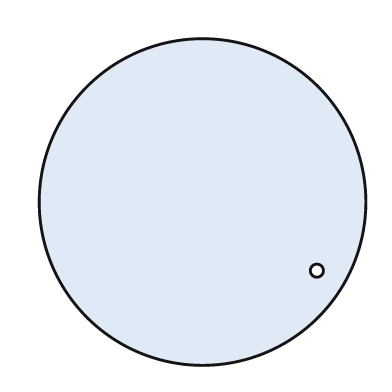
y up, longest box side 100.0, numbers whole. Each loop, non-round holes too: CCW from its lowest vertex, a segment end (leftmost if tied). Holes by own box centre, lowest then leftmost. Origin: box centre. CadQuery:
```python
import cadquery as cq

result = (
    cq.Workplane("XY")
    .moveTo(0.0, 0.0)
    .circle(50.0)
    .moveTo(35.0, -21.0)
    .circle(2.0)
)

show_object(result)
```